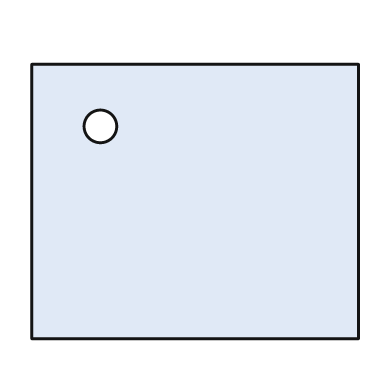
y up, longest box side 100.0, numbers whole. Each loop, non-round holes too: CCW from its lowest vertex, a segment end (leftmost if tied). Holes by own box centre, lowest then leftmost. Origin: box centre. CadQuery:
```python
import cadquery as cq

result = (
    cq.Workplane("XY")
    .moveTo(-50.0, -42.0)
    .lineTo(50.0, -42.0)
    .lineTo(50.0, 42.0)
    .lineTo(-50.0, 42.0)
    .close()
    .moveTo(-29.0, 23.0)
    .circle(5.0)
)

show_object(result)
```